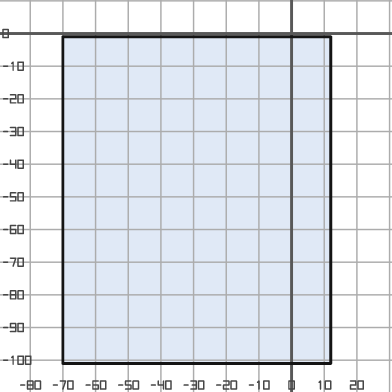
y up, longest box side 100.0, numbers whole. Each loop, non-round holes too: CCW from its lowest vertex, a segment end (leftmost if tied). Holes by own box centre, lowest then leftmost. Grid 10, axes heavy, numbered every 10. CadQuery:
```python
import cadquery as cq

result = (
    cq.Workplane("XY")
    .moveTo(-70.0, -101.0)
    .lineTo(12.0, -101.0)
    .lineTo(12.0, -1.0)
    .lineTo(-70.0, -1.0)
    .close()
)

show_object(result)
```